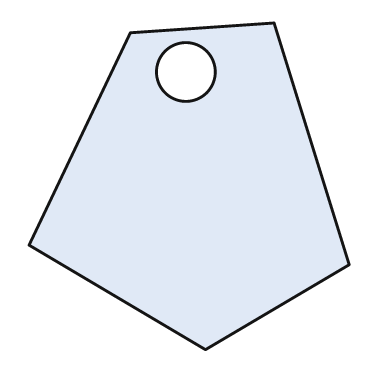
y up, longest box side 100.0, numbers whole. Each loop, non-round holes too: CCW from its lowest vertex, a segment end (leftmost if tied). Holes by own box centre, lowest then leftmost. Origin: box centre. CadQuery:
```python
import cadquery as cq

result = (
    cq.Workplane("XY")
    .moveTo(5.0, -50.0)
    .lineTo(49.0, -24.0)
    .lineTo(26.0, 50.0)
    .lineTo(-18.0, 47.0)
    .lineTo(-49.0, -18.0)
    .close()
    .moveTo(-1.0, 35.0)
    .circle(9.0)
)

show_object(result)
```